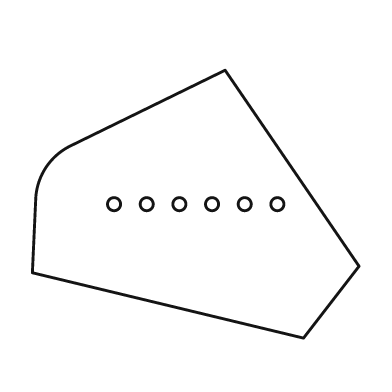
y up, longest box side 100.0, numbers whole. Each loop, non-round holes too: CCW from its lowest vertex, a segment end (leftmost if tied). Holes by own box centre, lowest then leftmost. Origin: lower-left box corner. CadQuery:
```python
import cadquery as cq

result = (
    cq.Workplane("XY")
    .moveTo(83.0, 0.0)
    .lineTo(100.0, 22.0)
    .lineTo(59.0, 82.0)
    .lineTo(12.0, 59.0)
    .threePointArc((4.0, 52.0), (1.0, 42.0))
    .lineTo(0.0, 20.0)
    .close()
    .moveTo(25.0, 41.0)
    .circle(2.0)
    .moveTo(35.0, 41.0)
    .circle(2.0)
    .moveTo(45.0, 41.0)
    .circle(2.0)
    .moveTo(55.0, 41.0)
    .circle(2.0)
    .moveTo(65.0, 41.0)
    .circle(2.0)
    .moveTo(75.0, 41.0)
    .circle(2.0)
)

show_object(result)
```